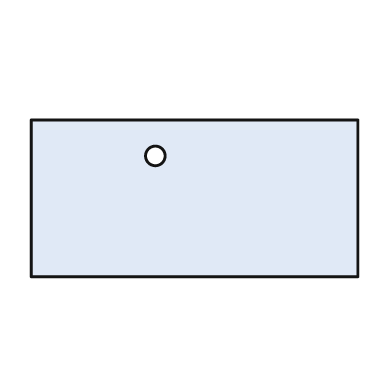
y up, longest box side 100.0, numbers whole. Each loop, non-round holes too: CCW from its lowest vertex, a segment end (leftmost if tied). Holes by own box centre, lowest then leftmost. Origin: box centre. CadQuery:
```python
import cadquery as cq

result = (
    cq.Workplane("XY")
    .moveTo(-50.0, -24.0)
    .lineTo(50.0, -24.0)
    .lineTo(50.0, 24.0)
    .lineTo(-50.0, 24.0)
    .close()
    .moveTo(-12.0, 13.0)
    .circle(3.0)
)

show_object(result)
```